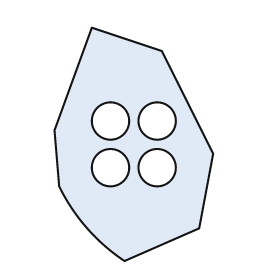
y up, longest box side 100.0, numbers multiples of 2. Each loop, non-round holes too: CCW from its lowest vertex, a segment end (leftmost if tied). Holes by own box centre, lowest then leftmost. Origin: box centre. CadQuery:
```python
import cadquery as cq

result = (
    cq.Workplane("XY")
    .moveTo(-4.0, -50.0)
    .lineTo(28.0, -36.0)
    .lineTo(34.0, -4.0)
    .lineTo(12.0, 40.0)
    .lineTo(-18.0, 50.0)
    .lineTo(-34.0, 6.0)
    .lineTo(-32.0, -18.0)
    .threePointArc((-20.0, -36.0), (-4.0, -50.0))
    .close()
    .moveTo(-10.0, -10.0)
    .circle(8.0)
    .moveTo(10.0, -10.0)
    .circle(8.0)
    .moveTo(-10.0, 10.0)
    .circle(8.0)
    .moveTo(10.0, 10.0)
    .circle(8.0)
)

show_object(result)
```